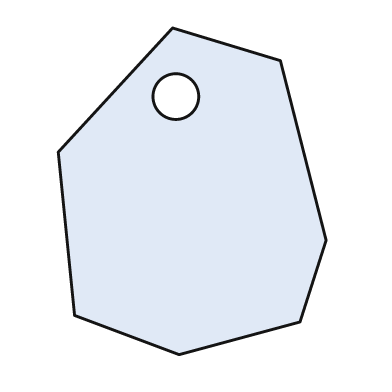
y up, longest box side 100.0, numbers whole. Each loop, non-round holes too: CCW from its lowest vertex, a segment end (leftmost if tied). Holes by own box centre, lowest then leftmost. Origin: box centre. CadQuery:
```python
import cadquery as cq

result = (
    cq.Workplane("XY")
    .moveTo(-4.0, -50.0)
    .lineTo(33.0, -40.0)
    .lineTo(41.0, -15.0)
    .lineTo(27.0, 40.0)
    .lineTo(-6.0, 50.0)
    .lineTo(-41.0, 12.0)
    .lineTo(-36.0, -38.0)
    .close()
    .moveTo(-5.0, 29.0)
    .circle(7.0)
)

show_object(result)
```